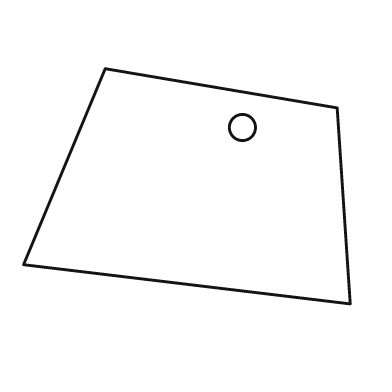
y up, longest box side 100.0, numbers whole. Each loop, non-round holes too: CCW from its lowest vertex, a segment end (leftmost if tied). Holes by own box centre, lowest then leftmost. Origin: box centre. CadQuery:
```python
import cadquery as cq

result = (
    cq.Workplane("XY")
    .moveTo(50.0, -36.0)
    .lineTo(46.0, 24.0)
    .lineTo(-25.0, 36.0)
    .lineTo(-50.0, -24.0)
    .close()
    .moveTo(17.0, 18.0)
    .circle(4.0)
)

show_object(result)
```